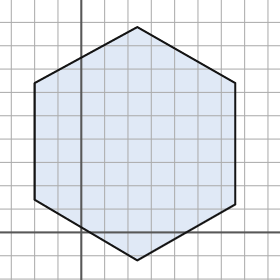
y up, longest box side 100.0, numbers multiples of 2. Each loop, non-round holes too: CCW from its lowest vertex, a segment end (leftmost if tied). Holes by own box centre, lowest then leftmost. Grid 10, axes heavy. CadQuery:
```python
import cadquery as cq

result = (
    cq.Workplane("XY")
    .moveTo(24.0, -12.0)
    .lineTo(66.0, 12.0)
    .lineTo(66.0, 64.0)
    .lineTo(24.0, 88.0)
    .lineTo(-20.0, 64.0)
    .lineTo(-20.0, 14.0)
    .close()
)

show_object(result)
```